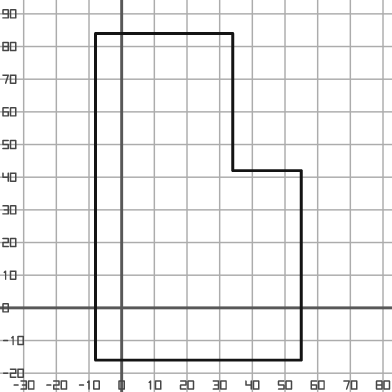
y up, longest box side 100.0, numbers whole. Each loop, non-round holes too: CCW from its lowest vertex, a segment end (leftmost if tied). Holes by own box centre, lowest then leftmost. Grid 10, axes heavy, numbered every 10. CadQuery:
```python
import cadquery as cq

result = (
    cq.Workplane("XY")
    .moveTo(-8.0, -16.0)
    .lineTo(55.0, -16.0)
    .lineTo(55.0, 42.0)
    .lineTo(34.0, 42.0)
    .lineTo(34.0, 84.0)
    .lineTo(-8.0, 84.0)
    .close()
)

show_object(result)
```